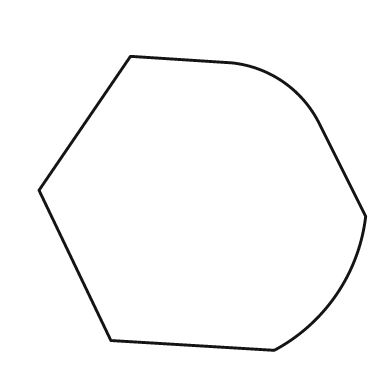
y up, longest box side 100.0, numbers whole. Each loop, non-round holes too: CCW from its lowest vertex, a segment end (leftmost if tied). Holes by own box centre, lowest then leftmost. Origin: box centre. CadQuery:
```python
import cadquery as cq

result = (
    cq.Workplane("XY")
    .moveTo(22.0, -45.0)
    .threePointArc((41.0, -28.0), (50.0, -4.0))
    .lineTo(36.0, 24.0)
    .threePointArc((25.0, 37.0), (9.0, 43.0))
    .lineTo(-22.0, 45.0)
    .lineTo(-50.0, 4.0)
    .lineTo(-28.0, -42.0)
    .close()
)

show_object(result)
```